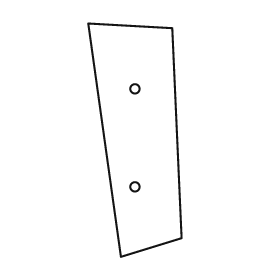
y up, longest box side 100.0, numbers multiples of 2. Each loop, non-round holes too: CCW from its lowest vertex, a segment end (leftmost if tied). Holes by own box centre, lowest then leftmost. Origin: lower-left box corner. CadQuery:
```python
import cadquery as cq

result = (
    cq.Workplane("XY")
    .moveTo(14.0, 0.0)
    .lineTo(40.0, 8.0)
    .lineTo(36.0, 98.0)
    .lineTo(0.0, 100.0)
    .close()
    .moveTo(20.0, 30.0)
    .circle(2.0)
    .moveTo(20.0, 72.0)
    .circle(2.0)
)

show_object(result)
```